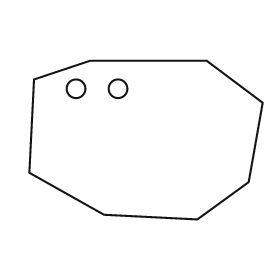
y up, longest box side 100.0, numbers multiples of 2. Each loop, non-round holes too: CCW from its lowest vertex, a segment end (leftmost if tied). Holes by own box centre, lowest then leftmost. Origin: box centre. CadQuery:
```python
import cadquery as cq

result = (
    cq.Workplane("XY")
    .moveTo(22.0, -34.0)
    .lineTo(44.0, -18.0)
    .lineTo(50.0, 16.0)
    .lineTo(26.0, 34.0)
    .lineTo(-24.0, 34.0)
    .lineTo(-48.0, 26.0)
    .lineTo(-50.0, -14.0)
    .lineTo(-18.0, -32.0)
    .close()
    .moveTo(-30.0, 22.0)
    .circle(4.0)
    .moveTo(-12.0, 22.0)
    .circle(4.0)
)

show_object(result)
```